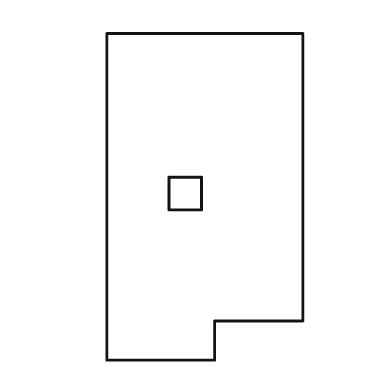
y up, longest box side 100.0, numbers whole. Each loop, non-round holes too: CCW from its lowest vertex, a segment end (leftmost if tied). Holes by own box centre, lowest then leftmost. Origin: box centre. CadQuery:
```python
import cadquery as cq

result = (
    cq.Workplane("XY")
    .moveTo(-30.0, -50.0)
    .lineTo(3.0, -50.0)
    .lineTo(3.0, -38.0)
    .lineTo(30.0, -38.0)
    .lineTo(30.0, 50.0)
    .lineTo(-30.0, 50.0)
    .close()
    .moveTo(-11.0, -4.0)
    .lineTo(-1.0, -4.0)
    .lineTo(-1.0, 6.0)
    .lineTo(-11.0, 6.0)
    .close()
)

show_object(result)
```